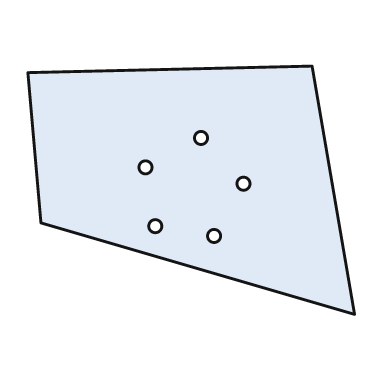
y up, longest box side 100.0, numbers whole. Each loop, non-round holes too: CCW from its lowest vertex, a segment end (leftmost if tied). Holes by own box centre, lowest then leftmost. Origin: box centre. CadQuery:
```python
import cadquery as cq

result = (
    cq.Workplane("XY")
    .moveTo(50.0, -38.0)
    .lineTo(37.0, 38.0)
    .lineTo(-50.0, 36.0)
    .lineTo(-46.0, -10.0)
    .close()
    .moveTo(7.0, -14.0)
    .circle(2.0)
    .moveTo(-11.0, -11.0)
    .circle(2.0)
    .moveTo(16.0, 2.0)
    .circle(2.0)
    .moveTo(-14.0, 7.0)
    .circle(2.0)
    .moveTo(3.0, 16.0)
    .circle(2.0)
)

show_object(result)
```